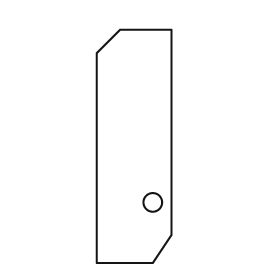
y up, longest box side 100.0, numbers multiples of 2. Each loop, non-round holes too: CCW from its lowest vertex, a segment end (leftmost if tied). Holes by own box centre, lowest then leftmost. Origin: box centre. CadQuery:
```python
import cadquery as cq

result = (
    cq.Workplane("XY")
    .moveTo(-16.0, -50.0)
    .lineTo(8.0, -50.0)
    .lineTo(16.0, -38.0)
    .lineTo(16.0, 50.0)
    .lineTo(-6.0, 50.0)
    .lineTo(-16.0, 40.0)
    .close()
    .moveTo(8.0, -24.0)
    .circle(4.0)
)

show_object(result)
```